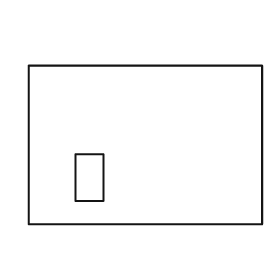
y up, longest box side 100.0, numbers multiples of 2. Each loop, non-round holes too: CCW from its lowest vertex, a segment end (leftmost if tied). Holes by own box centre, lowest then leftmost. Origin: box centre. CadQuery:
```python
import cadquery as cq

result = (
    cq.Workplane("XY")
    .moveTo(-50.0, -34.0)
    .lineTo(50.0, -34.0)
    .lineTo(50.0, 34.0)
    .lineTo(-50.0, 34.0)
    .close()
    .moveTo(-30.0, -24.0)
    .lineTo(-18.0, -24.0)
    .lineTo(-18.0, -4.0)
    .lineTo(-30.0, -4.0)
    .close()
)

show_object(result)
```